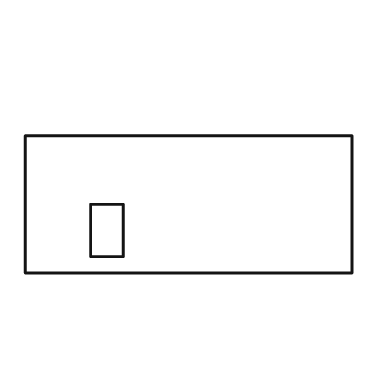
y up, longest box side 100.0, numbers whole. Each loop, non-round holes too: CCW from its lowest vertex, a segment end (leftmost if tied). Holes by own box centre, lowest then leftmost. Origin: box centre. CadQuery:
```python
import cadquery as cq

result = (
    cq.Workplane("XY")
    .moveTo(-50.0, -21.0)
    .lineTo(50.0, -21.0)
    .lineTo(50.0, 21.0)
    .lineTo(-50.0, 21.0)
    .close()
    .moveTo(-30.0, -16.0)
    .lineTo(-20.0, -16.0)
    .lineTo(-20.0, 0.0)
    .lineTo(-30.0, 0.0)
    .close()
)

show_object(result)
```